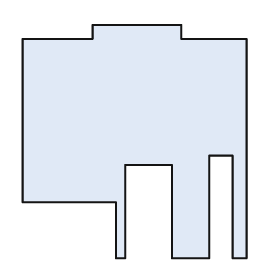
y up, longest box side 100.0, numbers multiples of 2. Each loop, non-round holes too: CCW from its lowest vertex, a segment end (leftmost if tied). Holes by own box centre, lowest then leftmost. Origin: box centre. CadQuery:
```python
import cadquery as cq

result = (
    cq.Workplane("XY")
    .moveTo(-8.0, -50.0)
    .lineTo(-4.0, -50.0)
    .lineTo(-4.0, -10.0)
    .lineTo(16.0, -10.0)
    .lineTo(16.0, -50.0)
    .lineTo(32.0, -50.0)
    .lineTo(32.0, -6.0)
    .lineTo(42.0, -6.0)
    .lineTo(42.0, -50.0)
    .lineTo(48.0, -50.0)
    .lineTo(48.0, 44.0)
    .lineTo(20.0, 44.0)
    .lineTo(20.0, 50.0)
    .lineTo(-18.0, 50.0)
    .lineTo(-18.0, 44.0)
    .lineTo(-48.0, 44.0)
    .lineTo(-48.0, -26.0)
    .lineTo(-8.0, -26.0)
    .close()
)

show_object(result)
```